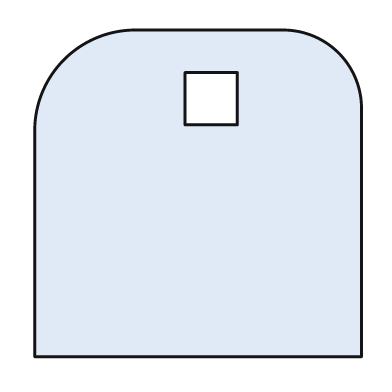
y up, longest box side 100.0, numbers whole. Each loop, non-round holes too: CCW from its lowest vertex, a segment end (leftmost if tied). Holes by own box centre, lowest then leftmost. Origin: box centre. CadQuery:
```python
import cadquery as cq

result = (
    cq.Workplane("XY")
    .moveTo(-50.0, -50.0)
    .lineTo(50.0, -50.0)
    .lineTo(50.0, 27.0)
    .threePointArc((43.0, 43.0), (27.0, 50.0))
    .lineTo(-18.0, 50.0)
    .threePointArc((-41.0, 41.0), (-50.0, 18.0))
    .close()
    .moveTo(-4.0, 21.0)
    .lineTo(12.0, 21.0)
    .lineTo(12.0, 37.0)
    .lineTo(-4.0, 37.0)
    .close()
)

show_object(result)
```